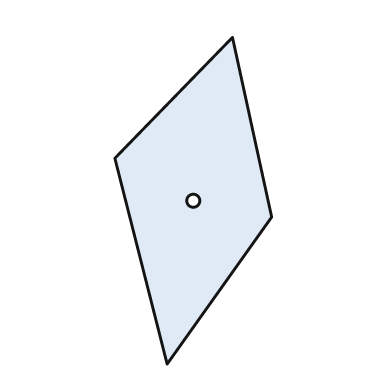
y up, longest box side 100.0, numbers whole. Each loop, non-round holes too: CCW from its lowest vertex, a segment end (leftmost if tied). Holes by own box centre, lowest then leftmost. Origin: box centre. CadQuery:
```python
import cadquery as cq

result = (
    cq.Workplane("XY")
    .moveTo(-8.0, -50.0)
    .lineTo(24.0, -5.0)
    .lineTo(12.0, 50.0)
    .lineTo(-24.0, 13.0)
    .close()
    .moveTo(0.0, 0.0)
    .circle(2.0)
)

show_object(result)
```